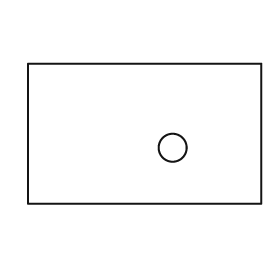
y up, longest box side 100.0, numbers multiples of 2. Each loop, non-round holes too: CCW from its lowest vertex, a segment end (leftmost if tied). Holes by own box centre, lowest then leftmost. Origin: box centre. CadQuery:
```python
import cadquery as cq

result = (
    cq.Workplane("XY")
    .moveTo(-50.0, -30.0)
    .lineTo(50.0, -30.0)
    .lineTo(50.0, 30.0)
    .lineTo(-50.0, 30.0)
    .close()
    .moveTo(12.0, -6.0)
    .circle(6.0)
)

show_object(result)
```